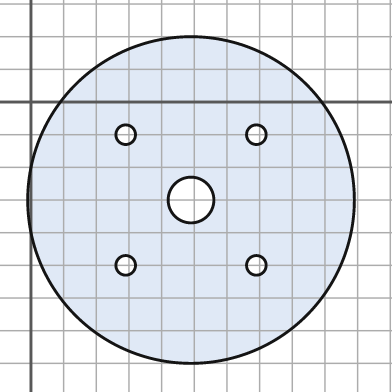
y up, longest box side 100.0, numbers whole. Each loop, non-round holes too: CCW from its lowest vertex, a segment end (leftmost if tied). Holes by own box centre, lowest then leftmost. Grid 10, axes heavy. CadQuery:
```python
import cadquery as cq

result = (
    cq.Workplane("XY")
    .moveTo(49.0, -30.0)
    .circle(50.0)
    .moveTo(29.0, -50.0)
    .circle(3.0)
    .moveTo(69.0, -50.0)
    .circle(3.0)
    .moveTo(49.0, -30.0)
    .circle(7.0)
    .moveTo(29.0, -10.0)
    .circle(3.0)
    .moveTo(69.0, -10.0)
    .circle(3.0)
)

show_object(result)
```